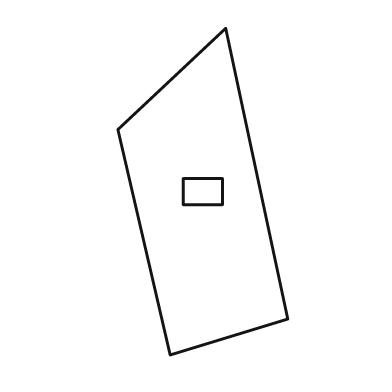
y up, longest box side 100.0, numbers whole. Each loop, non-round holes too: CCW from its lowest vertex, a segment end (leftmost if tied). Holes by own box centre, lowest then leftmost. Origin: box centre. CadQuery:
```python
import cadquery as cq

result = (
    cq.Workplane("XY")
    .moveTo(-10.0, -50.0)
    .lineTo(26.0, -39.0)
    .lineTo(7.0, 50.0)
    .lineTo(-26.0, 19.0)
    .close()
    .moveTo(-6.0, -4.0)
    .lineTo(6.0, -4.0)
    .lineTo(6.0, 4.0)
    .lineTo(-6.0, 4.0)
    .close()
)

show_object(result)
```